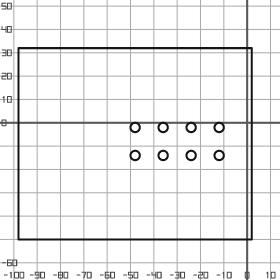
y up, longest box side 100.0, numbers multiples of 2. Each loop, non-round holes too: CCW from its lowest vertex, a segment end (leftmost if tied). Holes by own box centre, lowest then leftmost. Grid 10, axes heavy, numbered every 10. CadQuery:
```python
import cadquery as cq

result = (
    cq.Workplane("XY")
    .moveTo(-98.0, -50.0)
    .lineTo(2.0, -50.0)
    .lineTo(2.0, 32.0)
    .lineTo(-98.0, 32.0)
    .close()
    .moveTo(-48.0, -14.0)
    .circle(2.0)
    .moveTo(-36.0, -14.0)
    .circle(2.0)
    .moveTo(-24.0, -14.0)
    .circle(2.0)
    .moveTo(-12.0, -14.0)
    .circle(2.0)
    .moveTo(-48.0, -2.0)
    .circle(2.0)
    .moveTo(-36.0, -2.0)
    .circle(2.0)
    .moveTo(-24.0, -2.0)
    .circle(2.0)
    .moveTo(-12.0, -2.0)
    .circle(2.0)
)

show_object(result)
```